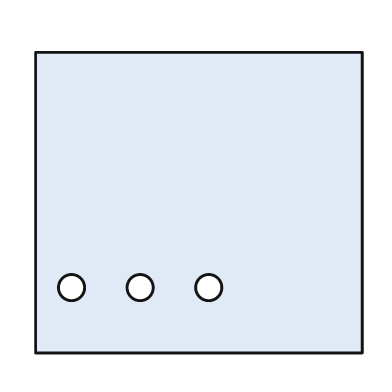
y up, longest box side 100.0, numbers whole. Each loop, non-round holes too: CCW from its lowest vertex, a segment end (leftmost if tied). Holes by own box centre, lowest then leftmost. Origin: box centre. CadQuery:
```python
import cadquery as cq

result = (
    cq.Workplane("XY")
    .moveTo(-50.0, -46.0)
    .lineTo(50.0, -46.0)
    .lineTo(50.0, 46.0)
    .lineTo(-50.0, 46.0)
    .close()
    .moveTo(-39.0, -26.0)
    .circle(4.0)
    .moveTo(-18.0, -26.0)
    .circle(4.0)
    .moveTo(3.0, -26.0)
    .circle(4.0)
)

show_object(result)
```